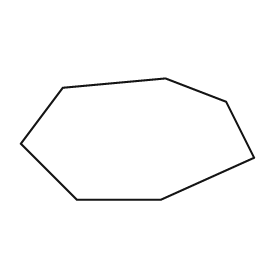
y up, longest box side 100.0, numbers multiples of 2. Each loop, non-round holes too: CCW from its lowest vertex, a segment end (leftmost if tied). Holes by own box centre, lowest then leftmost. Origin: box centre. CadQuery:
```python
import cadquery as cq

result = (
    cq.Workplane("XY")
    .moveTo(-26.0, -26.0)
    .lineTo(10.0, -26.0)
    .lineTo(50.0, -8.0)
    .lineTo(38.0, 16.0)
    .lineTo(12.0, 26.0)
    .lineTo(-32.0, 22.0)
    .lineTo(-50.0, -2.0)
    .close()
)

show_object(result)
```